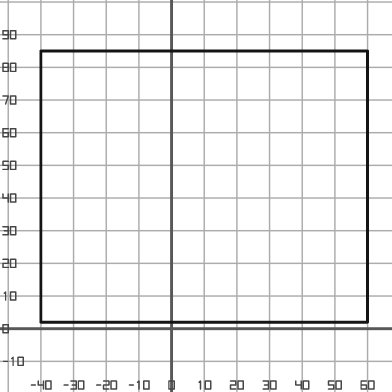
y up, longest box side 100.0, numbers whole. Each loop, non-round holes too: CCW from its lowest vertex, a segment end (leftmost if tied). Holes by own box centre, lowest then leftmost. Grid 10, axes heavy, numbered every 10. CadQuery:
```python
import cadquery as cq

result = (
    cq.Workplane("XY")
    .moveTo(-40.0, 2.0)
    .lineTo(60.0, 2.0)
    .lineTo(60.0, 85.0)
    .lineTo(-40.0, 85.0)
    .close()
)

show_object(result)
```